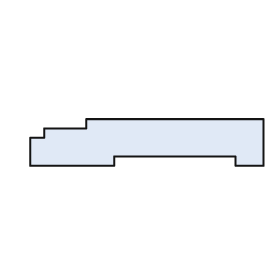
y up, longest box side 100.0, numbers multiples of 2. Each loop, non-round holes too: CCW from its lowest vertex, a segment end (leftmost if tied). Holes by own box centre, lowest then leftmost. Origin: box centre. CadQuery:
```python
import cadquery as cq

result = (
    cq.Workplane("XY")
    .moveTo(-50.0, -10.0)
    .lineTo(-14.0, -10.0)
    .lineTo(-14.0, -6.0)
    .lineTo(38.0, -6.0)
    .lineTo(38.0, -10.0)
    .lineTo(50.0, -10.0)
    .lineTo(50.0, 10.0)
    .lineTo(-26.0, 10.0)
    .lineTo(-26.0, 6.0)
    .lineTo(-44.0, 6.0)
    .lineTo(-44.0, 2.0)
    .lineTo(-50.0, 2.0)
    .close()
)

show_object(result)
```